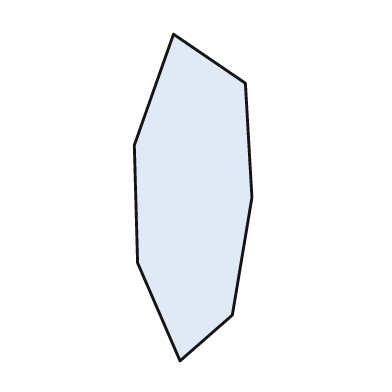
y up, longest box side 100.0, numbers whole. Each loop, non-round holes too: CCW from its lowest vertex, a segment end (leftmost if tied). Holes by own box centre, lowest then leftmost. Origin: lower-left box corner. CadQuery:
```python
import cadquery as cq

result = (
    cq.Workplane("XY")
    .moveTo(14.0, 0.0)
    .lineTo(30.0, 14.0)
    .lineTo(36.0, 50.0)
    .lineTo(34.0, 85.0)
    .lineTo(12.0, 100.0)
    .lineTo(0.0, 66.0)
    .lineTo(1.0, 30.0)
    .close()
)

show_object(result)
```